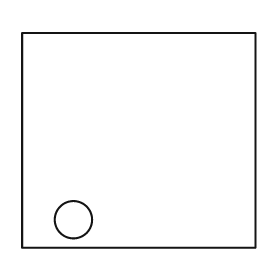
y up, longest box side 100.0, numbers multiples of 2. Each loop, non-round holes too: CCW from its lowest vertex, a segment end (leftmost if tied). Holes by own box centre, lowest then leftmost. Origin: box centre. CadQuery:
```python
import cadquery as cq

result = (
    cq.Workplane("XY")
    .moveTo(-50.0, -46.0)
    .lineTo(50.0, -46.0)
    .lineTo(50.0, 46.0)
    .lineTo(-50.0, 46.0)
    .close()
    .moveTo(-28.0, -34.0)
    .circle(8.0)
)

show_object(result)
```